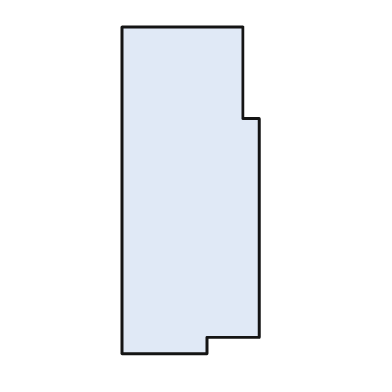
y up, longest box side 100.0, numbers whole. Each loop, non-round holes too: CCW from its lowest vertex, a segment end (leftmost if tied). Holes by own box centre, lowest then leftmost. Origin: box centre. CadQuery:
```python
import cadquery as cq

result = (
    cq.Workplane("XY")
    .moveTo(-21.0, -50.0)
    .lineTo(5.0, -50.0)
    .lineTo(5.0, -45.0)
    .lineTo(21.0, -45.0)
    .lineTo(21.0, 22.0)
    .lineTo(16.0, 22.0)
    .lineTo(16.0, 50.0)
    .lineTo(-21.0, 50.0)
    .close()
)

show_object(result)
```